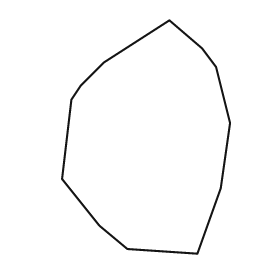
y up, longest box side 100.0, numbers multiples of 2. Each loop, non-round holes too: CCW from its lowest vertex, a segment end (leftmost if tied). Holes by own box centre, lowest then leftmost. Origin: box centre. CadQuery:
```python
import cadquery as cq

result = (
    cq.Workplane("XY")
    .moveTo(22.0, -50.0)
    .lineTo(32.0, -22.0)
    .lineTo(36.0, 6.0)
    .lineTo(30.0, 30.0)
    .lineTo(24.0, 38.0)
    .lineTo(10.0, 50.0)
    .lineTo(-18.0, 32.0)
    .lineTo(-28.0, 22.0)
    .lineTo(-32.0, 16.0)
    .lineTo(-36.0, -18.0)
    .lineTo(-20.0, -38.0)
    .lineTo(-8.0, -48.0)
    .close()
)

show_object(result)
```